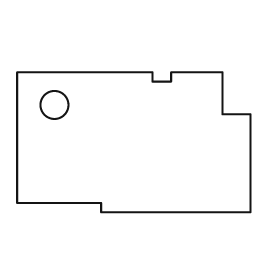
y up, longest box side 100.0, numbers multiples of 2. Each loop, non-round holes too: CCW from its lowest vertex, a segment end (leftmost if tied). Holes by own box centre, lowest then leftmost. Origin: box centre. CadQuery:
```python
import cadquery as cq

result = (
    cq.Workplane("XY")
    .moveTo(-14.0, -30.0)
    .lineTo(50.0, -30.0)
    .lineTo(50.0, 12.0)
    .lineTo(38.0, 12.0)
    .lineTo(38.0, 30.0)
    .lineTo(16.0, 30.0)
    .lineTo(16.0, 26.0)
    .lineTo(8.0, 26.0)
    .lineTo(8.0, 30.0)
    .lineTo(-50.0, 30.0)
    .lineTo(-50.0, -26.0)
    .lineTo(-14.0, -26.0)
    .close()
    .moveTo(-34.0, 16.0)
    .circle(6.0)
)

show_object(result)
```